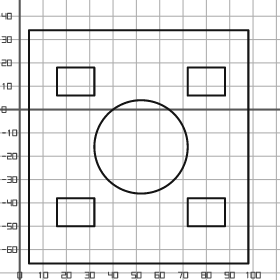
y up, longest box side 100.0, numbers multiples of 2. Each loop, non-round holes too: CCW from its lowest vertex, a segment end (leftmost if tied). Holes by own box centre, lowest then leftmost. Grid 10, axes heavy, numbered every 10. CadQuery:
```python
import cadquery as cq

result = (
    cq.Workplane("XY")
    .moveTo(4.0, -66.0)
    .lineTo(98.0, -66.0)
    .lineTo(98.0, 34.0)
    .lineTo(4.0, 34.0)
    .close()
    .moveTo(16.0, -50.0)
    .lineTo(32.0, -50.0)
    .lineTo(32.0, -38.0)
    .lineTo(16.0, -38.0)
    .close()
    .moveTo(72.0, -50.0)
    .lineTo(88.0, -50.0)
    .lineTo(88.0, -38.0)
    .lineTo(72.0, -38.0)
    .close()
    .moveTo(52.0, -16.0)
    .circle(20.0)
    .moveTo(16.0, 6.0)
    .lineTo(32.0, 6.0)
    .lineTo(32.0, 18.0)
    .lineTo(16.0, 18.0)
    .close()
    .moveTo(72.0, 6.0)
    .lineTo(88.0, 6.0)
    .lineTo(88.0, 18.0)
    .lineTo(72.0, 18.0)
    .close()
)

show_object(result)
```